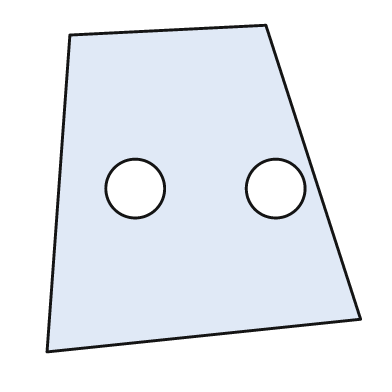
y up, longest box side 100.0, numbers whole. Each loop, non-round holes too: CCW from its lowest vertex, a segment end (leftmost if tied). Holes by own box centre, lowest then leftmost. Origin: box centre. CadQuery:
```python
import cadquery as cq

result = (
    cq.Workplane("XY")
    .moveTo(-48.0, -50.0)
    .lineTo(48.0, -40.0)
    .lineTo(19.0, 50.0)
    .lineTo(-41.0, 47.0)
    .close()
    .moveTo(-21.0, 0.0)
    .circle(9.0)
    .moveTo(22.0, 0.0)
    .circle(9.0)
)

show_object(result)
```